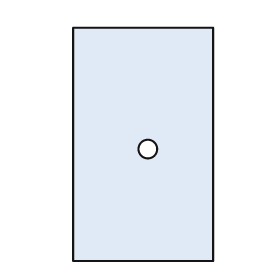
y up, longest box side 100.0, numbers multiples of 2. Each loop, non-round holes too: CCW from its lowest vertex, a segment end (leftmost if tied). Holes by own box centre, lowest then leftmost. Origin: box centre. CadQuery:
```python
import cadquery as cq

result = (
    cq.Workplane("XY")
    .moveTo(-30.0, -50.0)
    .lineTo(30.0, -50.0)
    .lineTo(30.0, 50.0)
    .lineTo(-30.0, 50.0)
    .close()
    .moveTo(2.0, -2.0)
    .circle(4.0)
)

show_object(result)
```